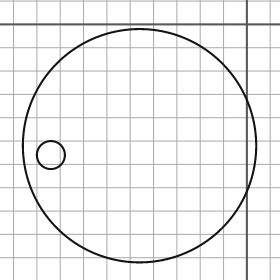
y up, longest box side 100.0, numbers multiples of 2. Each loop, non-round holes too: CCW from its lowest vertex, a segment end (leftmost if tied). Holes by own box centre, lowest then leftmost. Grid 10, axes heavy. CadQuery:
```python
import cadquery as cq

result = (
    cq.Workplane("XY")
    .moveTo(-46.0, -52.0)
    .circle(50.0)
    .moveTo(-84.0, -56.0)
    .circle(6.0)
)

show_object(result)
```